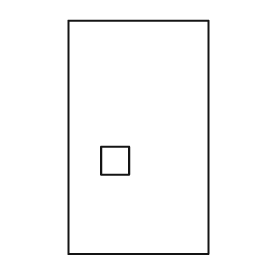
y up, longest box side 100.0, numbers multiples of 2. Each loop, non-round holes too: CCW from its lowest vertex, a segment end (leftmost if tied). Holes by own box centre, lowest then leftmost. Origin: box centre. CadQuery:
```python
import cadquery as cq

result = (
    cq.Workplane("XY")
    .moveTo(-30.0, -50.0)
    .lineTo(30.0, -50.0)
    .lineTo(30.0, 50.0)
    .lineTo(-30.0, 50.0)
    .close()
    .moveTo(-16.0, -16.0)
    .lineTo(-4.0, -16.0)
    .lineTo(-4.0, -4.0)
    .lineTo(-16.0, -4.0)
    .close()
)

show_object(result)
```